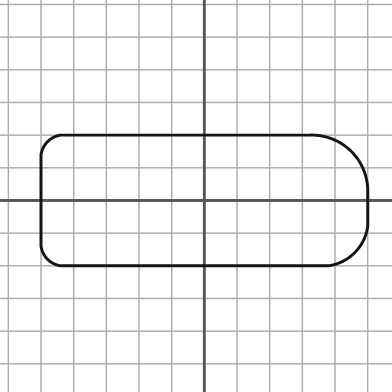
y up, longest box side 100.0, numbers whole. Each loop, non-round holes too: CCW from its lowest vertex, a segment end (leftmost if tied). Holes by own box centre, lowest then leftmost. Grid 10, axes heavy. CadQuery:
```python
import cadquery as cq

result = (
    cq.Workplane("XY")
    .moveTo(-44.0, -20.0)
    .lineTo(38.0, -20.0)
    .threePointArc((46.0, -16.0), (50.0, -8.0))
    .lineTo(50.0, 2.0)
    .threePointArc((45.0, 15.0), (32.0, 20.0))
    .lineTo(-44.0, 20.0)
    .threePointArc((-48.0, 18.0), (-50.0, 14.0))
    .lineTo(-50.0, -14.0)
    .threePointArc((-48.0, -18.0), (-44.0, -20.0))
    .close()
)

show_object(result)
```